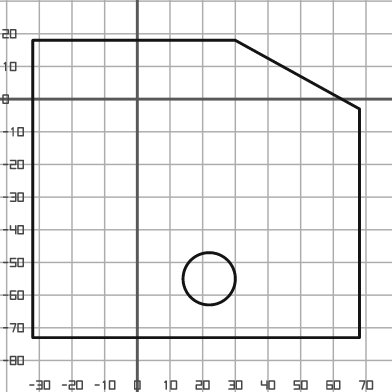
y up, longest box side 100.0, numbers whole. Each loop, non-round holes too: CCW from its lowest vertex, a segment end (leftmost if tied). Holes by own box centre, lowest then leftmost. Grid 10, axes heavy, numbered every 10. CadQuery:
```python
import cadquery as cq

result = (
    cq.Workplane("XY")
    .moveTo(-32.0, -73.0)
    .lineTo(68.0, -73.0)
    .lineTo(68.0, -3.0)
    .lineTo(30.0, 18.0)
    .lineTo(-32.0, 18.0)
    .close()
    .moveTo(22.0, -55.0)
    .circle(8.0)
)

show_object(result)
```